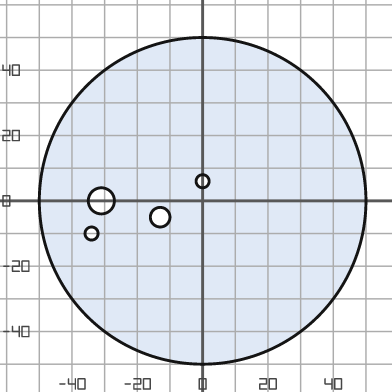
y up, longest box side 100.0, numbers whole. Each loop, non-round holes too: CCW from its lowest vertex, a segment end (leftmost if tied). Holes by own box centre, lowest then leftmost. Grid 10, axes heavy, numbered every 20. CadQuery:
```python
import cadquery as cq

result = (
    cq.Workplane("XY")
    .moveTo(0.0, 0.0)
    .circle(50.0)
    .moveTo(-34.0, -10.0)
    .circle(2.0)
    .moveTo(-13.0, -5.0)
    .circle(3.0)
    .moveTo(-31.0, 0.0)
    .circle(4.0)
    .moveTo(0.0, 6.0)
    .circle(2.0)
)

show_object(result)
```